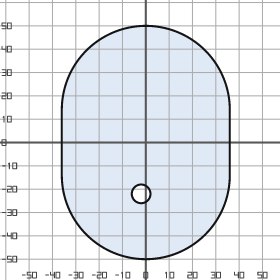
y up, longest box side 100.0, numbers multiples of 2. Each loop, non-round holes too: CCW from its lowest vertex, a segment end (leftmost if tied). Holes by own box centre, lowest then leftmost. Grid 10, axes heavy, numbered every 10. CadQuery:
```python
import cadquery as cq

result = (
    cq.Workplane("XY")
    .moveTo(-36.0, -14.0)
    .threePointArc((0.0, -50.0), (36.0, -14.0))
    .lineTo(36.0, 14.0)
    .threePointArc((0.0, 50.0), (-36.0, 14.0))
    .close()
    .moveTo(-2.0, -22.0)
    .circle(4.0)
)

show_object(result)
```